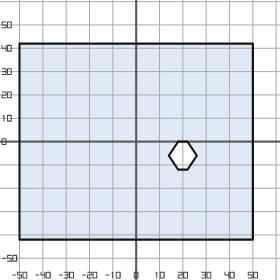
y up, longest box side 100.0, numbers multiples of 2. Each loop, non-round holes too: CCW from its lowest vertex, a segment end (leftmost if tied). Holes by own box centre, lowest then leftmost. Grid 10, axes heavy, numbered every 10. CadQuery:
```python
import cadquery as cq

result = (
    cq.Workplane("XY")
    .moveTo(-50.0, -42.0)
    .lineTo(50.0, -42.0)
    .lineTo(50.0, 42.0)
    .lineTo(-50.0, 42.0)
    .close()
    .moveTo(18.0, -12.0)
    .lineTo(22.0, -12.0)
    .lineTo(26.0, -6.0)
    .lineTo(22.0, 0.0)
    .lineTo(18.0, 0.0)
    .lineTo(14.0, -6.0)
    .close()
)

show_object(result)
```